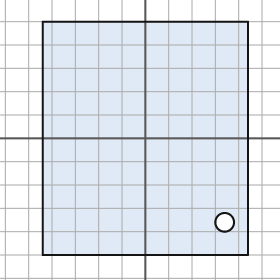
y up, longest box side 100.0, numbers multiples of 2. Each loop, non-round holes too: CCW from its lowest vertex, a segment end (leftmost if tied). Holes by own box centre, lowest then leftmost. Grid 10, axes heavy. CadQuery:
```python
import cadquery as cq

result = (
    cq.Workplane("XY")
    .moveTo(-44.0, -50.0)
    .lineTo(44.0, -50.0)
    .lineTo(44.0, 50.0)
    .lineTo(-44.0, 50.0)
    .close()
    .moveTo(34.0, -36.0)
    .circle(4.0)
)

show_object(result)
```